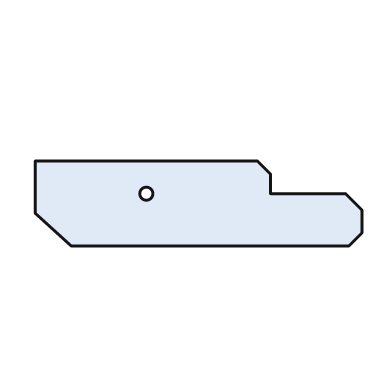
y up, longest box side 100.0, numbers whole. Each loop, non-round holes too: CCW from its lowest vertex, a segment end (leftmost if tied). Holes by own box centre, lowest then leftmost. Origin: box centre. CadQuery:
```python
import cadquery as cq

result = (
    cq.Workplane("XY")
    .moveTo(-39.0, -13.0)
    .lineTo(46.0, -13.0)
    .lineTo(50.0, -9.0)
    .lineTo(50.0, -2.0)
    .lineTo(45.0, 3.0)
    .lineTo(22.0, 3.0)
    .lineTo(22.0, 9.0)
    .lineTo(18.0, 13.0)
    .lineTo(-50.0, 13.0)
    .lineTo(-50.0, -3.0)
    .close()
    .moveTo(-16.0, 3.0)
    .circle(2.0)
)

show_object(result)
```